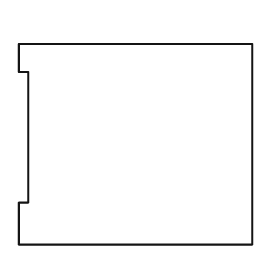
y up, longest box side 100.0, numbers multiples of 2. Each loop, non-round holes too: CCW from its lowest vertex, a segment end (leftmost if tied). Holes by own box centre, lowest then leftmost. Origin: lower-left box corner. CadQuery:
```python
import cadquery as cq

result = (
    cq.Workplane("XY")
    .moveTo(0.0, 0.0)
    .lineTo(100.0, 0.0)
    .lineTo(100.0, 86.0)
    .lineTo(0.0, 86.0)
    .lineTo(0.0, 74.0)
    .lineTo(4.0, 74.0)
    .lineTo(4.0, 18.0)
    .lineTo(0.0, 18.0)
    .close()
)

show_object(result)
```